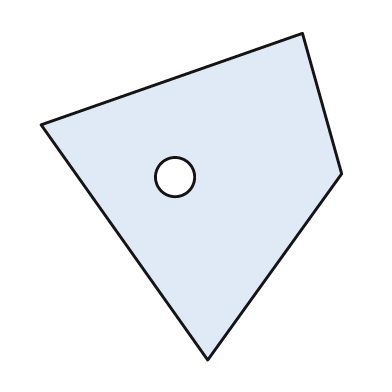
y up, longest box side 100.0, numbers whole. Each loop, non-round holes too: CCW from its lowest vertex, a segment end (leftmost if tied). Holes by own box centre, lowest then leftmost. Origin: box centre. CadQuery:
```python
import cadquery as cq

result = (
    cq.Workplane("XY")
    .moveTo(5.0, -50.0)
    .lineTo(46.0, 7.0)
    .lineTo(34.0, 50.0)
    .lineTo(-46.0, 22.0)
    .close()
    .moveTo(-5.0, 6.0)
    .circle(6.0)
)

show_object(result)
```